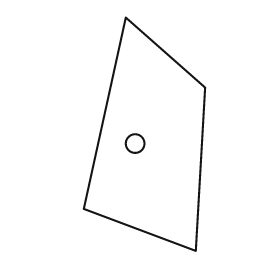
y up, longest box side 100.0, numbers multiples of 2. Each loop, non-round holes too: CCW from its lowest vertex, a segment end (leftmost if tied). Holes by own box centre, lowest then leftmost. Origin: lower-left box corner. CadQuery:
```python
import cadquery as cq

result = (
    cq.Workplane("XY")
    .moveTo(48.0, 0.0)
    .lineTo(52.0, 70.0)
    .lineTo(18.0, 100.0)
    .lineTo(0.0, 18.0)
    .close()
    .moveTo(22.0, 46.0)
    .circle(4.0)
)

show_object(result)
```